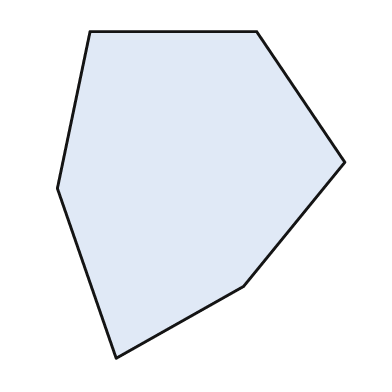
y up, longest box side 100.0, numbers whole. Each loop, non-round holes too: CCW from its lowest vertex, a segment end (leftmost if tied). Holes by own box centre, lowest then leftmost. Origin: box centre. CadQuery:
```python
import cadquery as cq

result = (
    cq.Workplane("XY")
    .moveTo(-26.0, -50.0)
    .lineTo(13.0, -28.0)
    .lineTo(44.0, 10.0)
    .lineTo(17.0, 50.0)
    .lineTo(-34.0, 50.0)
    .lineTo(-44.0, 2.0)
    .close()
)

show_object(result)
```